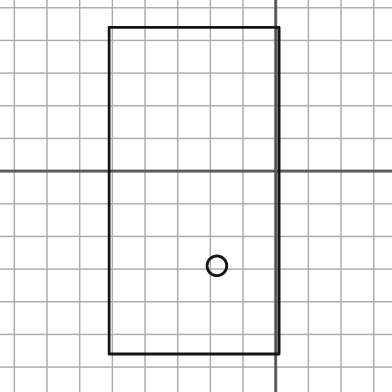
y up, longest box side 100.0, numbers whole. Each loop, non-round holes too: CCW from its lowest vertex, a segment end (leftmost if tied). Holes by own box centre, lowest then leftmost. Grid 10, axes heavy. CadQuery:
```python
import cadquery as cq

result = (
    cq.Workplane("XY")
    .moveTo(-51.0, -56.0)
    .lineTo(1.0, -56.0)
    .lineTo(1.0, 44.0)
    .lineTo(-51.0, 44.0)
    .close()
    .moveTo(-18.0, -29.0)
    .circle(3.0)
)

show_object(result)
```